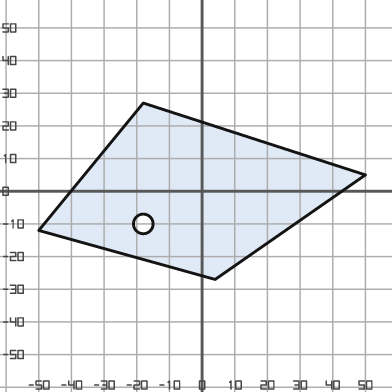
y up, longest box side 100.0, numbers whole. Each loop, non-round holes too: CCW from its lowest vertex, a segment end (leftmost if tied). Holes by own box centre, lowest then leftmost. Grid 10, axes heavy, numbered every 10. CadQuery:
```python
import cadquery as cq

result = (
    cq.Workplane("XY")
    .moveTo(4.0, -27.0)
    .lineTo(50.0, 5.0)
    .lineTo(-18.0, 27.0)
    .lineTo(-50.0, -12.0)
    .close()
    .moveTo(-18.0, -10.0)
    .circle(3.0)
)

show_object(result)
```